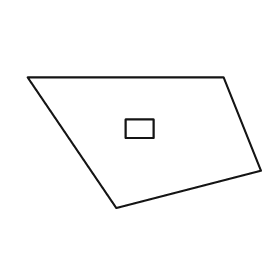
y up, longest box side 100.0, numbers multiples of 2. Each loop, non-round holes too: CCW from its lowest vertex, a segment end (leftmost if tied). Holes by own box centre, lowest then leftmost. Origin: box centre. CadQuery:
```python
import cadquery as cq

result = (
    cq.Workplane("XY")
    .moveTo(-12.0, -28.0)
    .lineTo(50.0, -12.0)
    .lineTo(34.0, 28.0)
    .lineTo(-50.0, 28.0)
    .close()
    .moveTo(-8.0, 2.0)
    .lineTo(4.0, 2.0)
    .lineTo(4.0, 10.0)
    .lineTo(-8.0, 10.0)
    .close()
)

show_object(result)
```